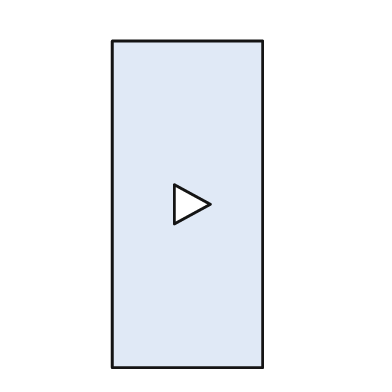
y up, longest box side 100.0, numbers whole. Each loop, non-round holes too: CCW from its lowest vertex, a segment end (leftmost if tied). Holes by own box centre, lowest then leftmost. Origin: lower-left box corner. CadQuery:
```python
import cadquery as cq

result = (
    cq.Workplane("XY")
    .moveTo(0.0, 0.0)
    .lineTo(46.0, 0.0)
    .lineTo(46.0, 100.0)
    .lineTo(0.0, 100.0)
    .close()
    .moveTo(19.0, 44.0)
    .lineTo(30.0, 50.0)
    .lineTo(19.0, 56.0)
    .close()
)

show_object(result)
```